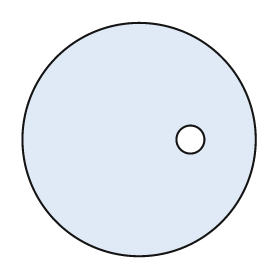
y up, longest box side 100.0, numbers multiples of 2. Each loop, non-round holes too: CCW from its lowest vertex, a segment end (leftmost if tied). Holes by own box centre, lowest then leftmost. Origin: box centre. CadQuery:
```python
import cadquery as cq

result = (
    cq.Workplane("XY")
    .moveTo(0.0, 0.0)
    .circle(50.0)
    .moveTo(22.0, 0.0)
    .circle(6.0)
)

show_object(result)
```